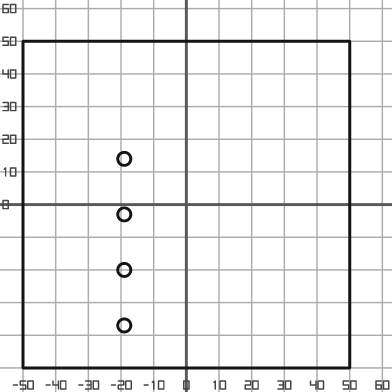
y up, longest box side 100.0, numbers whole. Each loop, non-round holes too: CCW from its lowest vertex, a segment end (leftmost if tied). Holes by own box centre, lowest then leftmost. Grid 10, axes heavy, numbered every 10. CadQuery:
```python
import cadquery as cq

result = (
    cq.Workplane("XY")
    .moveTo(-50.0, -50.0)
    .lineTo(50.0, -50.0)
    .lineTo(50.0, 50.0)
    .lineTo(-50.0, 50.0)
    .close()
    .moveTo(-19.0, -37.0)
    .circle(2.0)
    .moveTo(-19.0, -20.0)
    .circle(2.0)
    .moveTo(-19.0, -3.0)
    .circle(2.0)
    .moveTo(-19.0, 14.0)
    .circle(2.0)
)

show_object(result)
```